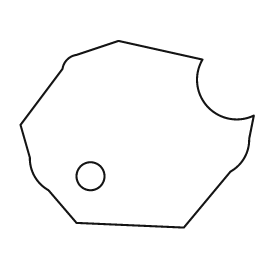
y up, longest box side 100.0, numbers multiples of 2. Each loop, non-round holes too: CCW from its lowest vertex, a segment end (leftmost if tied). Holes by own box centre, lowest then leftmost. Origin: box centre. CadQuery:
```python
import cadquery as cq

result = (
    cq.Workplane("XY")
    .moveTo(20.0, -40.0)
    .lineTo(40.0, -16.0)
    .threePointArc((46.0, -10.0), (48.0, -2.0))
    .lineTo(50.0, 8.0)
    .threePointArc((30.0, 12.0), (28.0, 32.0))
    .lineTo(-8.0, 40.0)
    .lineTo(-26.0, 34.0)
    .threePointArc((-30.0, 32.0), (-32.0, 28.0))
    .lineTo(-50.0, 4.0)
    .lineTo(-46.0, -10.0)
    .threePointArc((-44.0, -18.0), (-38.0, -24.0))
    .lineTo(-26.0, -38.0)
    .close()
    .moveTo(-20.0, -18.0)
    .circle(6.0)
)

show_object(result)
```